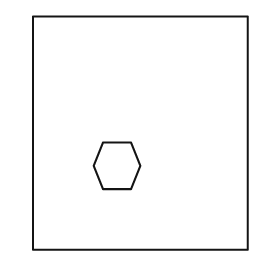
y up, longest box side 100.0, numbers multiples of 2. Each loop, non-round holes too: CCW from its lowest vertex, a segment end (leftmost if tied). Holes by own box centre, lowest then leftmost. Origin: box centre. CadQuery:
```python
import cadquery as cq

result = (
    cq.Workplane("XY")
    .moveTo(-46.0, -50.0)
    .lineTo(46.0, -50.0)
    .lineTo(46.0, 50.0)
    .lineTo(-46.0, 50.0)
    .close()
    .moveTo(-16.0, -24.0)
    .lineTo(-4.0, -24.0)
    .lineTo(0.0, -14.0)
    .lineTo(-4.0, -4.0)
    .lineTo(-16.0, -4.0)
    .lineTo(-20.0, -14.0)
    .close()
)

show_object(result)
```